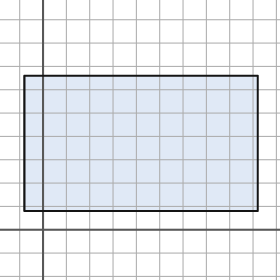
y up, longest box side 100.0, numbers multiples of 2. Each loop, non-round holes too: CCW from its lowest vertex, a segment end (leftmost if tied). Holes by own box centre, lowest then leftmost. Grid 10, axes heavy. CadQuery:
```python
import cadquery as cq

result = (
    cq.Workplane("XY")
    .moveTo(-8.0, 8.0)
    .lineTo(92.0, 8.0)
    .lineTo(92.0, 66.0)
    .lineTo(-8.0, 66.0)
    .close()
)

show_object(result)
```